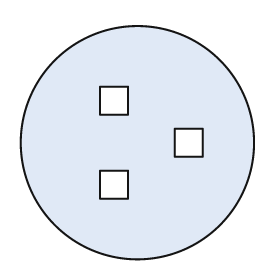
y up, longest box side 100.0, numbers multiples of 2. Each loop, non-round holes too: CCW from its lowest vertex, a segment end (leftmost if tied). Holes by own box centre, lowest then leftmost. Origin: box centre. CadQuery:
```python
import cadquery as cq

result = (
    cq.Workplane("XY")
    .moveTo(0.0, 0.0)
    .circle(50.0)
    .moveTo(-16.0, -24.0)
    .lineTo(-4.0, -24.0)
    .lineTo(-4.0, -12.0)
    .lineTo(-16.0, -12.0)
    .close()
    .moveTo(16.0, -6.0)
    .lineTo(28.0, -6.0)
    .lineTo(28.0, 6.0)
    .lineTo(16.0, 6.0)
    .close()
    .moveTo(-16.0, 12.0)
    .lineTo(-4.0, 12.0)
    .lineTo(-4.0, 24.0)
    .lineTo(-16.0, 24.0)
    .close()
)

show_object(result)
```